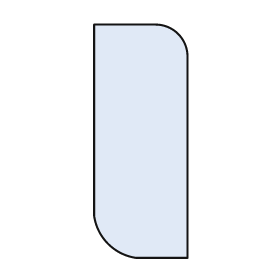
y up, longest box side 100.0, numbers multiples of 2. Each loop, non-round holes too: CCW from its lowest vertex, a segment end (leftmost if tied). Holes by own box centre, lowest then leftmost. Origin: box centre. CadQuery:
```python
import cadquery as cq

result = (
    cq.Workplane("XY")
    .moveTo(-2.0, -50.0)
    .lineTo(20.0, -50.0)
    .lineTo(20.0, 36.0)
    .threePointArc((16.0, 46.0), (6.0, 50.0))
    .lineTo(-20.0, 50.0)
    .lineTo(-20.0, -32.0)
    .threePointArc((-14.0, -44.0), (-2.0, -50.0))
    .close()
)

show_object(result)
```